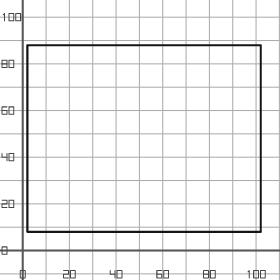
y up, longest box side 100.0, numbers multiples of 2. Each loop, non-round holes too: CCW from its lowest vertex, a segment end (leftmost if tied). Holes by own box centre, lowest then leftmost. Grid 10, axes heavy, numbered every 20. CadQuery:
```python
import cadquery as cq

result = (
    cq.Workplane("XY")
    .moveTo(2.0, 8.0)
    .lineTo(102.0, 8.0)
    .lineTo(102.0, 88.0)
    .lineTo(2.0, 88.0)
    .close()
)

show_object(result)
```